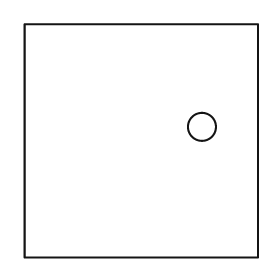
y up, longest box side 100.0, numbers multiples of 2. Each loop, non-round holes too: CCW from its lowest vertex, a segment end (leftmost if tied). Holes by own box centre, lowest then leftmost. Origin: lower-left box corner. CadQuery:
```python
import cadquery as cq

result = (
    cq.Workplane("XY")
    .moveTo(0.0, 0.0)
    .lineTo(100.0, 0.0)
    .lineTo(100.0, 100.0)
    .lineTo(0.0, 100.0)
    .close()
    .moveTo(76.0, 56.0)
    .circle(6.0)
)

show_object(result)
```